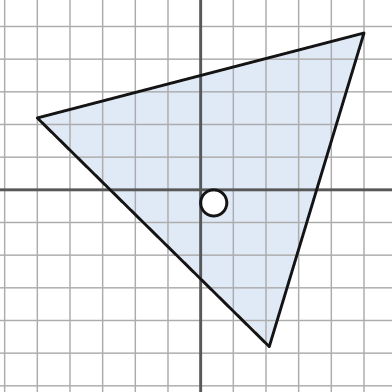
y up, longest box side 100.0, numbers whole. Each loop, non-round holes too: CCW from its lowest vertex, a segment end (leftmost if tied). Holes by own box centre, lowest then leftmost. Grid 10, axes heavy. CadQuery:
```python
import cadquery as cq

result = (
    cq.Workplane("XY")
    .moveTo(21.0, -48.0)
    .lineTo(50.0, 48.0)
    .lineTo(-50.0, 22.0)
    .close()
    .moveTo(4.0, -4.0)
    .circle(4.0)
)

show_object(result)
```